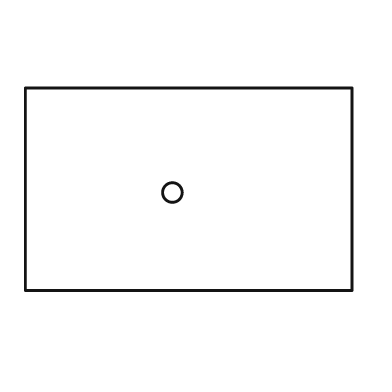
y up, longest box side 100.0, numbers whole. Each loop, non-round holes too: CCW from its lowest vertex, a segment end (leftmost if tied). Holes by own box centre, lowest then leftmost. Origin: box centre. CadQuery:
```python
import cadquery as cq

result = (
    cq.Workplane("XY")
    .moveTo(-50.0, -31.0)
    .lineTo(50.0, -31.0)
    .lineTo(50.0, 31.0)
    .lineTo(-50.0, 31.0)
    .close()
    .moveTo(-5.0, -1.0)
    .circle(3.0)
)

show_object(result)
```